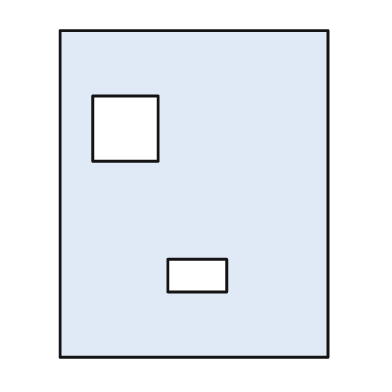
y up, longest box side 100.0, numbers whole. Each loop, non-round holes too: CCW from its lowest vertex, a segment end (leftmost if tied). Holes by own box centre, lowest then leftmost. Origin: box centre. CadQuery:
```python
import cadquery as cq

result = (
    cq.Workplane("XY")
    .moveTo(-41.0, -50.0)
    .lineTo(41.0, -50.0)
    .lineTo(41.0, 50.0)
    .lineTo(-41.0, 50.0)
    .close()
    .moveTo(-8.0, -30.0)
    .lineTo(10.0, -30.0)
    .lineTo(10.0, -20.0)
    .lineTo(-8.0, -20.0)
    .close()
    .moveTo(-31.0, 10.0)
    .lineTo(-11.0, 10.0)
    .lineTo(-11.0, 30.0)
    .lineTo(-31.0, 30.0)
    .close()
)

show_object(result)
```